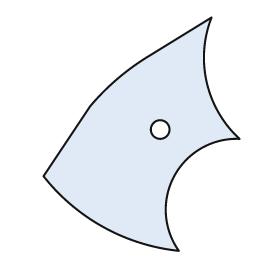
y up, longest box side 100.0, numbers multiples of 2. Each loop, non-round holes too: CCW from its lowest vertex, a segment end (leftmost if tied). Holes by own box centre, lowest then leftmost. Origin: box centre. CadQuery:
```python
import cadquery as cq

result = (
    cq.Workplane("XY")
    .moveTo(16.0, -50.0)
    .threePointArc((14.0, -18.0), (42.0, -2.0))
    .threePointArc((28.0, 22.0), (30.0, 50.0))
    .lineTo(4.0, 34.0)
    .threePointArc((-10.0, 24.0), (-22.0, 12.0))
    .lineTo(-42.0, -18.0)
    .threePointArc((-16.0, -40.0), (16.0, -50.0))
    .close()
    .moveTo(8.0, 2.0)
    .circle(4.0)
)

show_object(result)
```